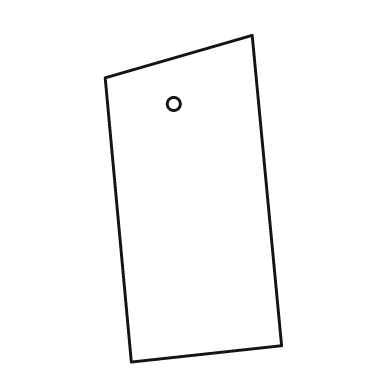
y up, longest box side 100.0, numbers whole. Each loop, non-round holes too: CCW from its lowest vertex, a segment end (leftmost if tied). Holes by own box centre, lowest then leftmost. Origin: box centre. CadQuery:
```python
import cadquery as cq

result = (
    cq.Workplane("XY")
    .moveTo(-19.0, -50.0)
    .lineTo(27.0, -45.0)
    .lineTo(18.0, 50.0)
    .lineTo(-27.0, 37.0)
    .close()
    .moveTo(-6.0, 29.0)
    .circle(2.0)
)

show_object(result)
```